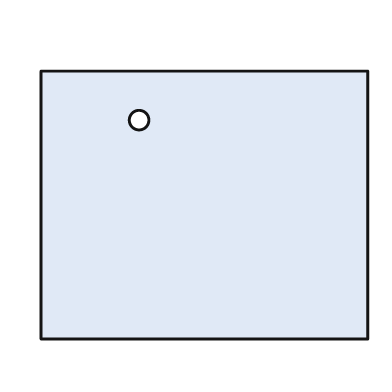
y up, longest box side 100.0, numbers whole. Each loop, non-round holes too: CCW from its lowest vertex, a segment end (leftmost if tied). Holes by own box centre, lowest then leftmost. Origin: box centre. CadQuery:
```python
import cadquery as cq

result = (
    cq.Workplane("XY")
    .moveTo(-50.0, -41.0)
    .lineTo(50.0, -41.0)
    .lineTo(50.0, 41.0)
    .lineTo(-50.0, 41.0)
    .close()
    .moveTo(-20.0, 26.0)
    .circle(3.0)
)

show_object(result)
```